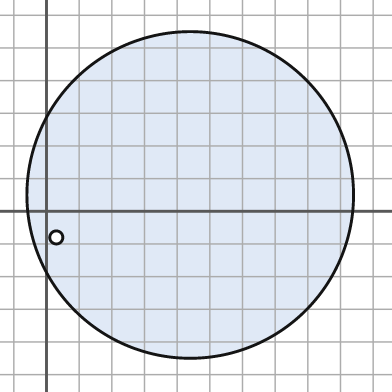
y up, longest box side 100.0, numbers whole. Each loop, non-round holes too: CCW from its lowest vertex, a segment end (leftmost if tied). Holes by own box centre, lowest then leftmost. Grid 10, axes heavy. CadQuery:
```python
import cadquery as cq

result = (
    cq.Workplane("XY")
    .moveTo(44.0, 5.0)
    .circle(50.0)
    .moveTo(3.0, -8.0)
    .circle(2.0)
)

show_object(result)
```